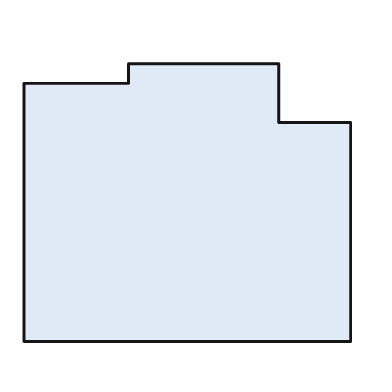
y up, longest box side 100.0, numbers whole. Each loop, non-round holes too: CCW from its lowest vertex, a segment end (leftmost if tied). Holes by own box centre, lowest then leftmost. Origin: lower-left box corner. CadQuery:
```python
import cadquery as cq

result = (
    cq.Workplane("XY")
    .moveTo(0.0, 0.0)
    .lineTo(100.0, 0.0)
    .lineTo(100.0, 67.0)
    .lineTo(78.0, 67.0)
    .lineTo(78.0, 85.0)
    .lineTo(32.0, 85.0)
    .lineTo(32.0, 79.0)
    .lineTo(0.0, 79.0)
    .close()
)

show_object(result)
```